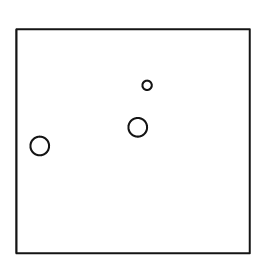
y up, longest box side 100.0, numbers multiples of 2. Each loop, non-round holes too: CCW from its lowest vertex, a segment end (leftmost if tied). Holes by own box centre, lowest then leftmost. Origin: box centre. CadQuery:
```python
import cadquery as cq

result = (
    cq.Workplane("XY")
    .moveTo(-50.0, -48.0)
    .lineTo(50.0, -48.0)
    .lineTo(50.0, 48.0)
    .lineTo(-50.0, 48.0)
    .close()
    .moveTo(-40.0, -2.0)
    .circle(4.0)
    .moveTo(2.0, 6.0)
    .circle(4.0)
    .moveTo(6.0, 24.0)
    .circle(2.0)
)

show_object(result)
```